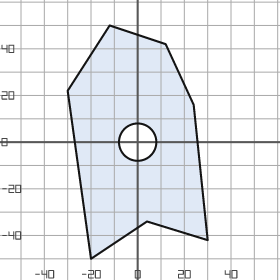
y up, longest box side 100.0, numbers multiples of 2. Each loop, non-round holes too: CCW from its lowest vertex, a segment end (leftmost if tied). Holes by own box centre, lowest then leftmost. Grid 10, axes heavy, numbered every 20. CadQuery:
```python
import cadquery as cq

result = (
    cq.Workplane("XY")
    .moveTo(-20.0, -50.0)
    .lineTo(4.0, -34.0)
    .lineTo(30.0, -42.0)
    .lineTo(24.0, 16.0)
    .lineTo(12.0, 42.0)
    .lineTo(-12.0, 50.0)
    .lineTo(-30.0, 22.0)
    .close()
    .moveTo(0.0, 0.0)
    .circle(8.0)
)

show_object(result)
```